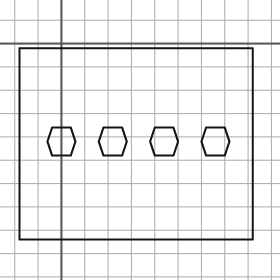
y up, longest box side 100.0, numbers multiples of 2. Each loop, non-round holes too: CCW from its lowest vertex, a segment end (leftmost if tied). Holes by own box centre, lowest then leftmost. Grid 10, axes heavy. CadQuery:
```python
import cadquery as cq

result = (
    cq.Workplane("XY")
    .moveTo(-18.0, -84.0)
    .lineTo(82.0, -84.0)
    .lineTo(82.0, -2.0)
    .lineTo(-18.0, -2.0)
    .close()
    .moveTo(-4.0, -48.0)
    .lineTo(4.0, -48.0)
    .lineTo(6.0, -42.0)
    .lineTo(4.0, -36.0)
    .lineTo(-4.0, -36.0)
    .lineTo(-6.0, -42.0)
    .close()
    .moveTo(18.0, -48.0)
    .lineTo(26.0, -48.0)
    .lineTo(28.0, -42.0)
    .lineTo(26.0, -36.0)
    .lineTo(18.0, -36.0)
    .lineTo(16.0, -42.0)
    .close()
    .moveTo(40.0, -48.0)
    .lineTo(48.0, -48.0)
    .lineTo(50.0, -42.0)
    .lineTo(48.0, -36.0)
    .lineTo(40.0, -36.0)
    .lineTo(38.0, -42.0)
    .close()
    .moveTo(62.0, -48.0)
    .lineTo(70.0, -48.0)
    .lineTo(72.0, -42.0)
    .lineTo(70.0, -36.0)
    .lineTo(62.0, -36.0)
    .lineTo(60.0, -42.0)
    .close()
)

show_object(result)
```